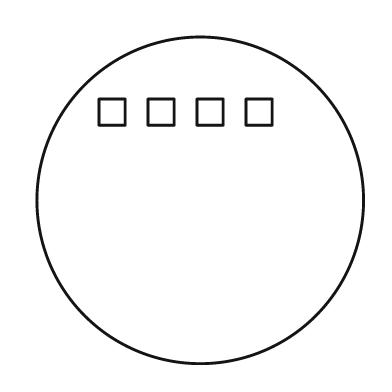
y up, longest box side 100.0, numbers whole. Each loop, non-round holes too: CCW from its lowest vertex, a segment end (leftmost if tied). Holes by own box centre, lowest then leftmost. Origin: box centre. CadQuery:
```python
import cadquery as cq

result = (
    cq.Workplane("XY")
    .moveTo(0.0, 0.0)
    .circle(50.0)
    .moveTo(-31.0, 23.0)
    .lineTo(-23.0, 23.0)
    .lineTo(-23.0, 31.0)
    .lineTo(-31.0, 31.0)
    .close()
    .moveTo(-16.0, 23.0)
    .lineTo(-8.0, 23.0)
    .lineTo(-8.0, 31.0)
    .lineTo(-16.0, 31.0)
    .close()
    .moveTo(-1.0, 23.0)
    .lineTo(7.0, 23.0)
    .lineTo(7.0, 31.0)
    .lineTo(-1.0, 31.0)
    .close()
    .moveTo(14.0, 23.0)
    .lineTo(22.0, 23.0)
    .lineTo(22.0, 31.0)
    .lineTo(14.0, 31.0)
    .close()
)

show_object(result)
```